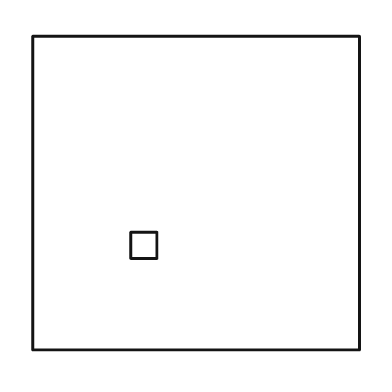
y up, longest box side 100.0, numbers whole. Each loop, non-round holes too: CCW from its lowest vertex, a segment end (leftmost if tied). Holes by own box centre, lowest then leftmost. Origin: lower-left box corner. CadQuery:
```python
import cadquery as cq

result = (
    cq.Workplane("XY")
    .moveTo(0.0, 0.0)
    .lineTo(100.0, 0.0)
    .lineTo(100.0, 96.0)
    .lineTo(0.0, 96.0)
    .close()
    .moveTo(30.0, 28.0)
    .lineTo(38.0, 28.0)
    .lineTo(38.0, 36.0)
    .lineTo(30.0, 36.0)
    .close()
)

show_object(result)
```